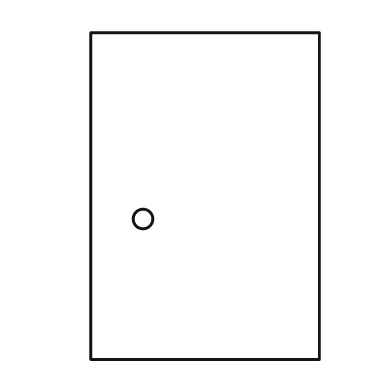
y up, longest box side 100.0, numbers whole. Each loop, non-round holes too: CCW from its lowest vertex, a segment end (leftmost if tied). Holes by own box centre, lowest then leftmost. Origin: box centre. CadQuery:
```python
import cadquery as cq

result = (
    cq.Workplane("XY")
    .moveTo(-35.0, -50.0)
    .lineTo(35.0, -50.0)
    .lineTo(35.0, 50.0)
    .lineTo(-35.0, 50.0)
    .close()
    .moveTo(-19.0, -7.0)
    .circle(3.0)
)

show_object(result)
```